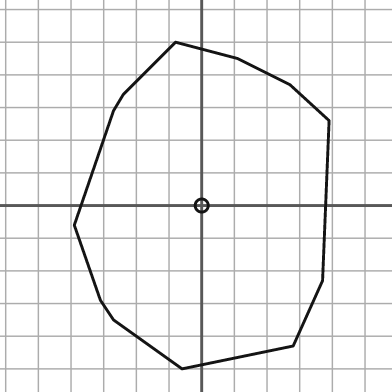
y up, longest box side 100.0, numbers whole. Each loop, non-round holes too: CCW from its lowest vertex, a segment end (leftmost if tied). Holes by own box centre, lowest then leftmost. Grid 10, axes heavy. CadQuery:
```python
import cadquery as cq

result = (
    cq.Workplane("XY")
    .moveTo(-6.0, -50.0)
    .lineTo(28.0, -43.0)
    .lineTo(37.0, -23.0)
    .lineTo(39.0, 26.0)
    .lineTo(27.0, 37.0)
    .lineTo(11.0, 45.0)
    .lineTo(-8.0, 50.0)
    .lineTo(-24.0, 34.0)
    .lineTo(-27.0, 29.0)
    .lineTo(-39.0, -6.0)
    .lineTo(-31.0, -29.0)
    .lineTo(-27.0, -35.0)
    .close()
    .moveTo(0.0, 0.0)
    .circle(2.0)
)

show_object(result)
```